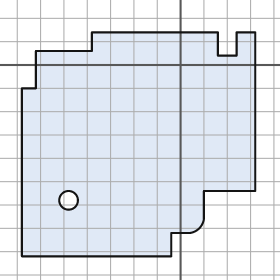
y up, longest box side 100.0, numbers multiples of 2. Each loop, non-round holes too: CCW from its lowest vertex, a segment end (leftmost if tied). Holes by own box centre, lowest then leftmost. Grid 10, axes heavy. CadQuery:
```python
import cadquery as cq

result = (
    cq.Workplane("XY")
    .moveTo(-68.0, -82.0)
    .lineTo(-4.0, -82.0)
    .lineTo(-4.0, -72.0)
    .lineTo(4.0, -72.0)
    .threePointArc((8.0, -70.0), (10.0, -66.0))
    .lineTo(10.0, -54.0)
    .lineTo(32.0, -54.0)
    .lineTo(32.0, 14.0)
    .lineTo(24.0, 14.0)
    .lineTo(24.0, 4.0)
    .lineTo(16.0, 4.0)
    .lineTo(16.0, 14.0)
    .lineTo(-38.0, 14.0)
    .lineTo(-38.0, 6.0)
    .lineTo(-62.0, 6.0)
    .lineTo(-62.0, -10.0)
    .lineTo(-68.0, -10.0)
    .close()
    .moveTo(-48.0, -58.0)
    .circle(4.0)
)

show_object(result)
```